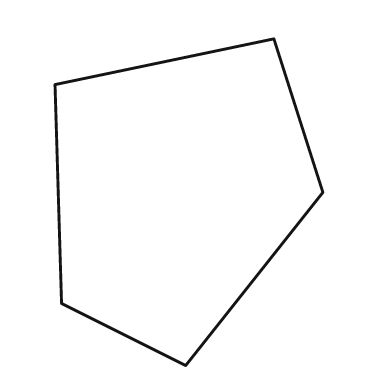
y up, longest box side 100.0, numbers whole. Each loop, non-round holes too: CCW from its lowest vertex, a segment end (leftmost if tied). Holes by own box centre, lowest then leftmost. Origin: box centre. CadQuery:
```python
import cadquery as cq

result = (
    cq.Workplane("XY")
    .moveTo(-1.0, -50.0)
    .lineTo(41.0, 3.0)
    .lineTo(26.0, 50.0)
    .lineTo(-41.0, 36.0)
    .lineTo(-39.0, -31.0)
    .close()
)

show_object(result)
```